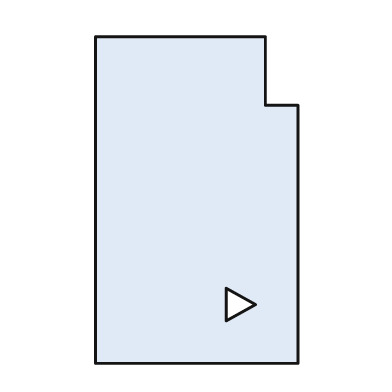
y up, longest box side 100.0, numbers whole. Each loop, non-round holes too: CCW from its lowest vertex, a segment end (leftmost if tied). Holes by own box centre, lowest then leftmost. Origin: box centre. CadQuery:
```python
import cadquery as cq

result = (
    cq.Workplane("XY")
    .moveTo(-31.0, -50.0)
    .lineTo(31.0, -50.0)
    .lineTo(31.0, 29.0)
    .lineTo(21.0, 29.0)
    .lineTo(21.0, 50.0)
    .lineTo(-31.0, 50.0)
    .close()
    .moveTo(9.0, -37.0)
    .lineTo(18.0, -32.0)
    .lineTo(9.0, -27.0)
    .close()
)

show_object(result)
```